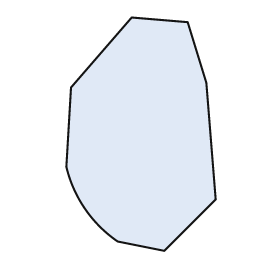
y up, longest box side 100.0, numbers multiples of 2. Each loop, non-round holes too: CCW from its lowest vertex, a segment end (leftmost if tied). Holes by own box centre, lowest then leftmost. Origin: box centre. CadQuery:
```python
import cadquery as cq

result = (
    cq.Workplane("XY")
    .moveTo(10.0, -50.0)
    .lineTo(32.0, -28.0)
    .lineTo(28.0, 22.0)
    .lineTo(20.0, 48.0)
    .lineTo(-4.0, 50.0)
    .lineTo(-30.0, 20.0)
    .lineTo(-32.0, -14.0)
    .threePointArc((-24.0, -32.0), (-10.0, -46.0))
    .close()
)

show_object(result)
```